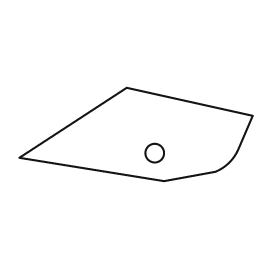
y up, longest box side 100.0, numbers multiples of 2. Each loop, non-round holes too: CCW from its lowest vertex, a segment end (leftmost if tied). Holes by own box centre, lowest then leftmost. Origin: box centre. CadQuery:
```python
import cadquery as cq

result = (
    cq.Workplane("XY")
    .moveTo(12.0, -20.0)
    .lineTo(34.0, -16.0)
    .threePointArc((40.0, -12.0), (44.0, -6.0))
    .lineTo(50.0, 8.0)
    .lineTo(-4.0, 20.0)
    .lineTo(-50.0, -10.0)
    .close()
    .moveTo(8.0, -8.0)
    .circle(4.0)
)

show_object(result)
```